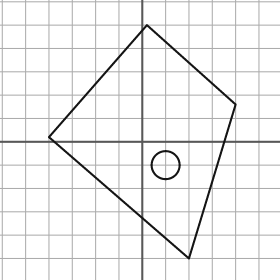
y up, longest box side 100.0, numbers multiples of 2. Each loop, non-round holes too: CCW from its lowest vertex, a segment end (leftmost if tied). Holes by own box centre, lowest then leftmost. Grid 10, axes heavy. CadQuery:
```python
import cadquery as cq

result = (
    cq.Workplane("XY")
    .moveTo(20.0, -50.0)
    .lineTo(40.0, 16.0)
    .lineTo(2.0, 50.0)
    .lineTo(-40.0, 2.0)
    .close()
    .moveTo(10.0, -10.0)
    .circle(6.0)
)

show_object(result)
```